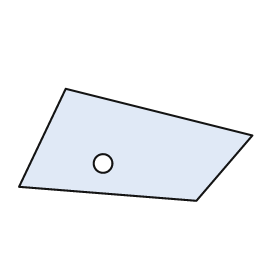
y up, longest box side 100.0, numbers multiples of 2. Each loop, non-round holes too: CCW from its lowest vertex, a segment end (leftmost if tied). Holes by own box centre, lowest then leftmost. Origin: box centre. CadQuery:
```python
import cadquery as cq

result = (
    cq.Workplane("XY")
    .moveTo(26.0, -24.0)
    .lineTo(50.0, 4.0)
    .lineTo(-30.0, 24.0)
    .lineTo(-50.0, -18.0)
    .close()
    .moveTo(-14.0, -8.0)
    .circle(4.0)
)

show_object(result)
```